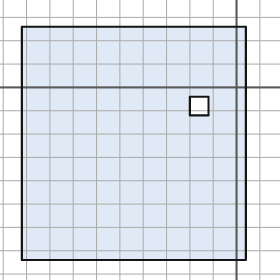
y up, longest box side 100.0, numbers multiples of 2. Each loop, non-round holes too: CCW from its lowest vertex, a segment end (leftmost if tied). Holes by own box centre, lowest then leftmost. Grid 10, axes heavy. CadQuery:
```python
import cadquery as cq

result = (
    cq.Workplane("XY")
    .moveTo(-92.0, -74.0)
    .lineTo(4.0, -74.0)
    .lineTo(4.0, 26.0)
    .lineTo(-92.0, 26.0)
    .close()
    .moveTo(-20.0, -12.0)
    .lineTo(-12.0, -12.0)
    .lineTo(-12.0, -4.0)
    .lineTo(-20.0, -4.0)
    .close()
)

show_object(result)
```